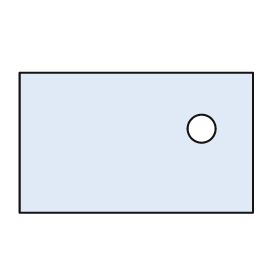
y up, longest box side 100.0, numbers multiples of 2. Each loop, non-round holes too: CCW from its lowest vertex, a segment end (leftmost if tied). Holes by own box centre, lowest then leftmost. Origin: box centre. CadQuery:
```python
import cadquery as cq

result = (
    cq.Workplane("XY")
    .moveTo(-50.0, -30.0)
    .lineTo(50.0, -30.0)
    .lineTo(50.0, 30.0)
    .lineTo(-50.0, 30.0)
    .close()
    .moveTo(28.0, 6.0)
    .circle(6.0)
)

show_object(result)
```